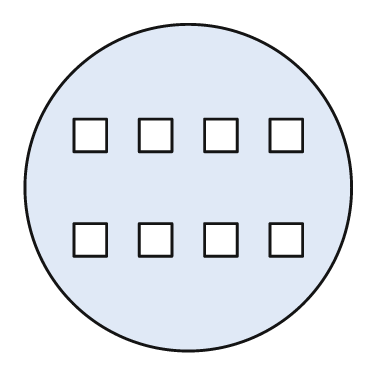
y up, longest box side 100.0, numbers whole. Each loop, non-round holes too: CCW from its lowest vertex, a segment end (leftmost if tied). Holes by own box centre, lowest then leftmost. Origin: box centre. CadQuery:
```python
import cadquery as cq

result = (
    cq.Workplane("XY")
    .moveTo(0.0, 0.0)
    .circle(50.0)
    .moveTo(-35.0, -21.0)
    .lineTo(-25.0, -21.0)
    .lineTo(-25.0, -11.0)
    .lineTo(-35.0, -11.0)
    .close()
    .moveTo(-15.0, -21.0)
    .lineTo(-5.0, -21.0)
    .lineTo(-5.0, -11.0)
    .lineTo(-15.0, -11.0)
    .close()
    .moveTo(5.0, -21.0)
    .lineTo(15.0, -21.0)
    .lineTo(15.0, -11.0)
    .lineTo(5.0, -11.0)
    .close()
    .moveTo(25.0, -21.0)
    .lineTo(35.0, -21.0)
    .lineTo(35.0, -11.0)
    .lineTo(25.0, -11.0)
    .close()
    .moveTo(-35.0, 11.0)
    .lineTo(-25.0, 11.0)
    .lineTo(-25.0, 21.0)
    .lineTo(-35.0, 21.0)
    .close()
    .moveTo(-15.0, 11.0)
    .lineTo(-5.0, 11.0)
    .lineTo(-5.0, 21.0)
    .lineTo(-15.0, 21.0)
    .close()
    .moveTo(5.0, 11.0)
    .lineTo(15.0, 11.0)
    .lineTo(15.0, 21.0)
    .lineTo(5.0, 21.0)
    .close()
    .moveTo(25.0, 11.0)
    .lineTo(35.0, 11.0)
    .lineTo(35.0, 21.0)
    .lineTo(25.0, 21.0)
    .close()
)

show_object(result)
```